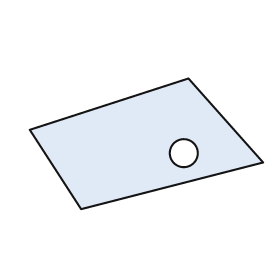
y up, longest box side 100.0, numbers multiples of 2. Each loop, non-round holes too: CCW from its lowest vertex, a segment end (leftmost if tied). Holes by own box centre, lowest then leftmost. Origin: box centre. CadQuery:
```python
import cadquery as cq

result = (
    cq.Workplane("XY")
    .moveTo(-28.0, -28.0)
    .lineTo(50.0, -8.0)
    .lineTo(18.0, 28.0)
    .lineTo(-50.0, 6.0)
    .close()
    .moveTo(16.0, -4.0)
    .circle(6.0)
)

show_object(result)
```